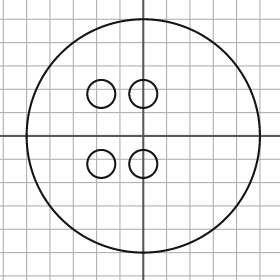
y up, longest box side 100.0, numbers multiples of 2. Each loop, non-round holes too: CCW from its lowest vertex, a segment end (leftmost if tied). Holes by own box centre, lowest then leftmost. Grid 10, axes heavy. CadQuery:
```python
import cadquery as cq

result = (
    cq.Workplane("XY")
    .moveTo(0.0, 0.0)
    .circle(50.0)
    .moveTo(-18.0, -12.0)
    .circle(6.0)
    .moveTo(0.0, -12.0)
    .circle(6.0)
    .moveTo(-18.0, 18.0)
    .circle(6.0)
    .moveTo(0.0, 18.0)
    .circle(6.0)
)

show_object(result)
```